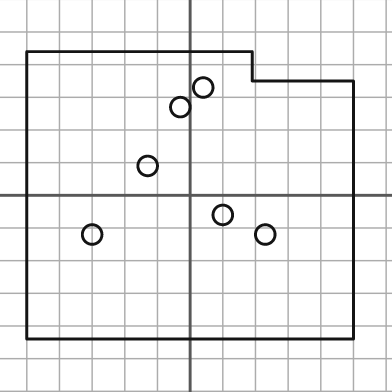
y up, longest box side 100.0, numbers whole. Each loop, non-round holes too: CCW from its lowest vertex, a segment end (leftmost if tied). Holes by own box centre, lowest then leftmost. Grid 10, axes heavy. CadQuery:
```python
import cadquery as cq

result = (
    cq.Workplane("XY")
    .moveTo(-50.0, -44.0)
    .lineTo(50.0, -44.0)
    .lineTo(50.0, 35.0)
    .lineTo(19.0, 35.0)
    .lineTo(19.0, 44.0)
    .lineTo(-50.0, 44.0)
    .close()
    .moveTo(-30.0, -12.0)
    .circle(3.0)
    .moveTo(23.0, -12.0)
    .circle(3.0)
    .moveTo(10.0, -6.0)
    .circle(3.0)
    .moveTo(-13.0, 9.0)
    .circle(3.0)
    .moveTo(-3.0, 27.0)
    .circle(3.0)
    .moveTo(4.0, 33.0)
    .circle(3.0)
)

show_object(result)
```